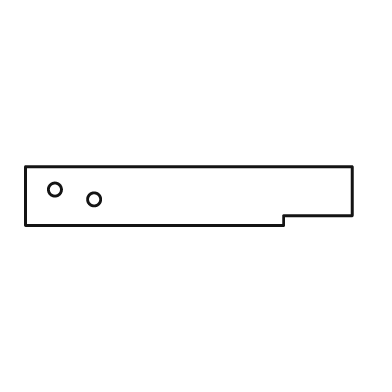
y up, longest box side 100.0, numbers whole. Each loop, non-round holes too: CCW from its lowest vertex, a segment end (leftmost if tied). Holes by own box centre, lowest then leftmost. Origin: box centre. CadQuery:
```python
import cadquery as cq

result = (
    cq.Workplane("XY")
    .moveTo(-50.0, -9.0)
    .lineTo(29.0, -9.0)
    .lineTo(29.0, -6.0)
    .lineTo(50.0, -6.0)
    .lineTo(50.0, 9.0)
    .lineTo(-50.0, 9.0)
    .close()
    .moveTo(-29.0, -1.0)
    .circle(2.0)
    .moveTo(-41.0, 2.0)
    .circle(2.0)
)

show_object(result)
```